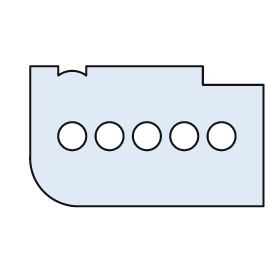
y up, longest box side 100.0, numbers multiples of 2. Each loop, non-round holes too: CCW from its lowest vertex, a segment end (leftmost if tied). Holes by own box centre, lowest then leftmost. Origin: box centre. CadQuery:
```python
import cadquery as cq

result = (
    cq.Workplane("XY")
    .moveTo(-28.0, -30.0)
    .lineTo(50.0, -30.0)
    .lineTo(50.0, 22.0)
    .lineTo(24.0, 22.0)
    .lineTo(24.0, 30.0)
    .lineTo(-26.0, 30.0)
    .lineTo(-26.0, 26.0)
    .threePointArc((-32.0, 28.0), (-38.0, 26.0))
    .lineTo(-38.0, 30.0)
    .lineTo(-50.0, 30.0)
    .lineTo(-50.0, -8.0)
    .threePointArc((-44.0, -24.0), (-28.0, -30.0))
    .close()
    .moveTo(-32.0, 0.0)
    .circle(6.0)
    .moveTo(-16.0, 0.0)
    .circle(6.0)
    .moveTo(0.0, 0.0)
    .circle(6.0)
    .moveTo(16.0, 0.0)
    .circle(6.0)
    .moveTo(32.0, 0.0)
    .circle(6.0)
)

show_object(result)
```